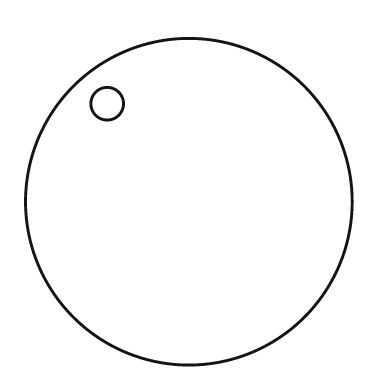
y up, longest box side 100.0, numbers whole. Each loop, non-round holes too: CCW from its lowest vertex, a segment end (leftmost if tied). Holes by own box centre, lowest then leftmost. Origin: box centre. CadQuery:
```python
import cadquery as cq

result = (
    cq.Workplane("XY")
    .moveTo(0.0, 0.0)
    .circle(50.0)
    .moveTo(-25.0, 30.0)
    .circle(5.0)
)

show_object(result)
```